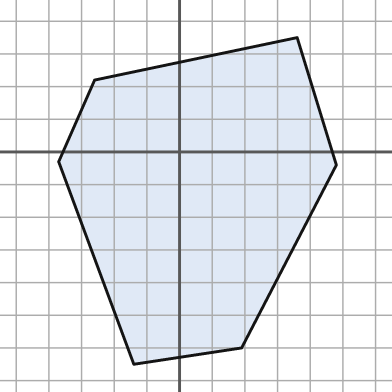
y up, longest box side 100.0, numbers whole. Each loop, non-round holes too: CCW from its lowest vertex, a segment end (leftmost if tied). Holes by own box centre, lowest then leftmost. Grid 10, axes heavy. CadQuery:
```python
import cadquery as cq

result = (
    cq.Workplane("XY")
    .moveTo(-14.0, -65.0)
    .lineTo(19.0, -60.0)
    .lineTo(48.0, -4.0)
    .lineTo(36.0, 35.0)
    .lineTo(-26.0, 22.0)
    .lineTo(-37.0, -3.0)
    .close()
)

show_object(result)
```